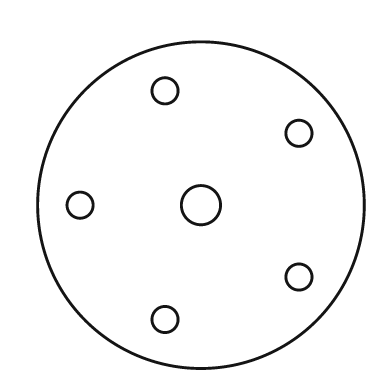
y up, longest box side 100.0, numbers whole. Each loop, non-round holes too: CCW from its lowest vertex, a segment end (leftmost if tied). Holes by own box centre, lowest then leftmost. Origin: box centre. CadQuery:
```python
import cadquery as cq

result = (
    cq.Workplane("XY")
    .moveTo(0.0, 0.0)
    .circle(50.0)
    .moveTo(-11.0, -35.0)
    .circle(4.0)
    .moveTo(30.0, -22.0)
    .circle(4.0)
    .moveTo(-37.0, 0.0)
    .circle(4.0)
    .moveTo(0.0, 0.0)
    .circle(6.0)
    .moveTo(30.0, 22.0)
    .circle(4.0)
    .moveTo(-11.0, 35.0)
    .circle(4.0)
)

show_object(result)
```